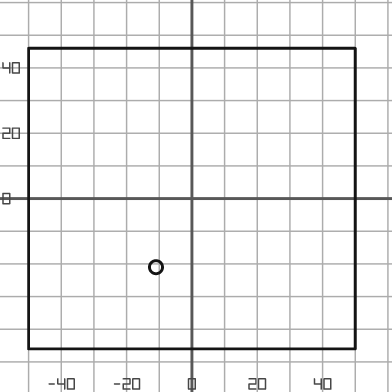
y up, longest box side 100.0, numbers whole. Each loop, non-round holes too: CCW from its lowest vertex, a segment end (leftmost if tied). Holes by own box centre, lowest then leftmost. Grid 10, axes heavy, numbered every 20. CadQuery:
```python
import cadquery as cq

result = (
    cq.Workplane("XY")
    .moveTo(-50.0, -46.0)
    .lineTo(50.0, -46.0)
    .lineTo(50.0, 46.0)
    .lineTo(-50.0, 46.0)
    .close()
    .moveTo(-11.0, -21.0)
    .circle(2.0)
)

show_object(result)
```